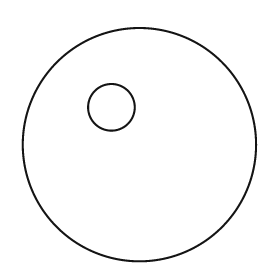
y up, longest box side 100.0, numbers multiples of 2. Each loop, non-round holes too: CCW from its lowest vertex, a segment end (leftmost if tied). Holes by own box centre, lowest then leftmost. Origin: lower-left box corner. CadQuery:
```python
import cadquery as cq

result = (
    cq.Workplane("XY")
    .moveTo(50.0, 50.0)
    .circle(50.0)
    .moveTo(38.0, 66.0)
    .circle(10.0)
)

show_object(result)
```